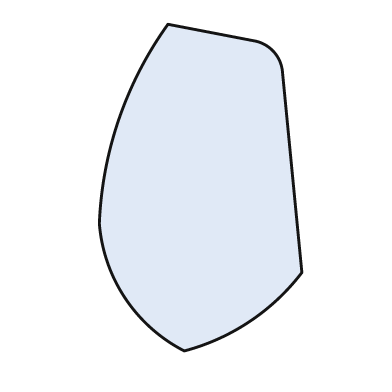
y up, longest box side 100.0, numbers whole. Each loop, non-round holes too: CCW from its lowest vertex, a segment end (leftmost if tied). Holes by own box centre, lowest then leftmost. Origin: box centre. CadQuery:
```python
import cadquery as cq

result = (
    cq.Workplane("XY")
    .moveTo(-5.0, -50.0)
    .threePointArc((15.0, -41.0), (31.0, -26.0))
    .lineTo(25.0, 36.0)
    .threePointArc((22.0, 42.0), (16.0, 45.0))
    .lineTo(-10.0, 50.0)
    .threePointArc((-25.0, 21.0), (-31.0, -11.0))
    .threePointArc((-23.0, -34.0), (-5.0, -50.0))
    .close()
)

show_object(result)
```